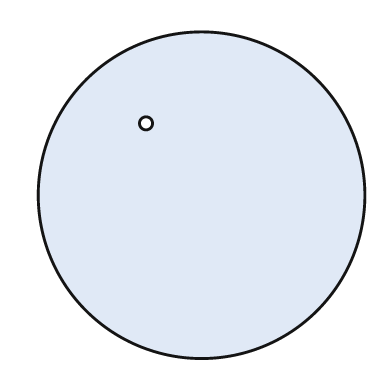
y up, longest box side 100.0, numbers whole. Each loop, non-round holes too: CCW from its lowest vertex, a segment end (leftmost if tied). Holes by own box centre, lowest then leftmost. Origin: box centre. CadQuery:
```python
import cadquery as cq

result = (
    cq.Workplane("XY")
    .moveTo(0.0, 0.0)
    .circle(50.0)
    .moveTo(-17.0, 22.0)
    .circle(2.0)
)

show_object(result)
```